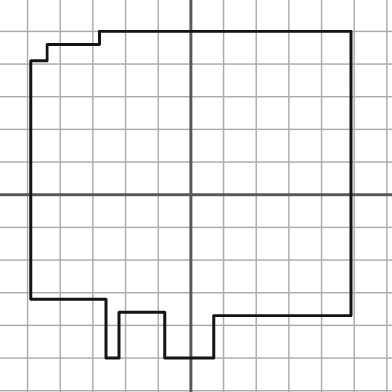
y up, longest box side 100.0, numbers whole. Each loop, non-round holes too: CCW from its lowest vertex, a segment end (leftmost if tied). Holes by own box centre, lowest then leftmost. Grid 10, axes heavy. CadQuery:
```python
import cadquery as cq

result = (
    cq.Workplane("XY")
    .moveTo(-26.0, -50.0)
    .lineTo(-22.0, -50.0)
    .lineTo(-22.0, -36.0)
    .lineTo(-8.0, -36.0)
    .lineTo(-8.0, -50.0)
    .lineTo(7.0, -50.0)
    .lineTo(7.0, -37.0)
    .lineTo(49.0, -37.0)
    .lineTo(49.0, 50.0)
    .lineTo(-28.0, 50.0)
    .lineTo(-28.0, 46.0)
    .lineTo(-44.0, 46.0)
    .lineTo(-44.0, 41.0)
    .lineTo(-49.0, 41.0)
    .lineTo(-49.0, -32.0)
    .lineTo(-26.0, -32.0)
    .close()
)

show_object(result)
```